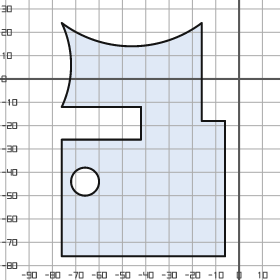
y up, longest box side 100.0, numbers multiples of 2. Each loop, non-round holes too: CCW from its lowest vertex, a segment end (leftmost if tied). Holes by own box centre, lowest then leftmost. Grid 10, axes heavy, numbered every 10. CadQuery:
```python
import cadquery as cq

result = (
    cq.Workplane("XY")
    .moveTo(-76.0, -76.0)
    .lineTo(-6.0, -76.0)
    .lineTo(-6.0, -18.0)
    .lineTo(-16.0, -18.0)
    .lineTo(-16.0, 24.0)
    .threePointArc((-46.0, 14.0), (-76.0, 24.0))
    .threePointArc((-72.0, 6.0), (-76.0, -12.0))
    .lineTo(-42.0, -12.0)
    .lineTo(-42.0, -26.0)
    .lineTo(-76.0, -26.0)
    .close()
    .moveTo(-66.0, -44.0)
    .circle(6.0)
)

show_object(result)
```